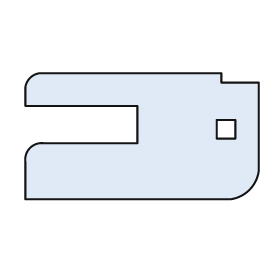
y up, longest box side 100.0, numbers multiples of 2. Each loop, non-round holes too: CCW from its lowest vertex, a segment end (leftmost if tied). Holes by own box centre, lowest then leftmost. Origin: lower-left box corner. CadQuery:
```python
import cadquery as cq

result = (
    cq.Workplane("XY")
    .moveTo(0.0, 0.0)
    .lineTo(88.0, 0.0)
    .threePointArc((96.0, 4.0), (100.0, 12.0))
    .lineTo(100.0, 50.0)
    .lineTo(84.0, 50.0)
    .lineTo(84.0, 54.0)
    .lineTo(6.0, 54.0)
    .threePointArc((2.0, 52.0), (0.0, 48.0))
    .lineTo(0.0, 40.0)
    .lineTo(48.0, 40.0)
    .lineTo(48.0, 24.0)
    .lineTo(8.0, 24.0)
    .threePointArc((2.0, 22.0), (0.0, 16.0))
    .close()
    .moveTo(82.0, 26.0)
    .lineTo(90.0, 26.0)
    .lineTo(90.0, 34.0)
    .lineTo(82.0, 34.0)
    .close()
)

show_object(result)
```